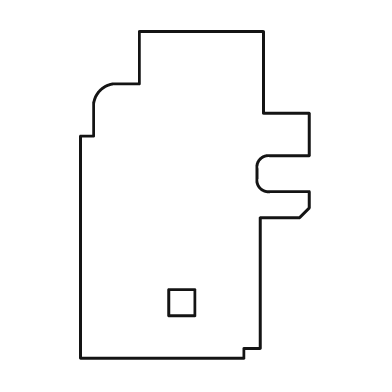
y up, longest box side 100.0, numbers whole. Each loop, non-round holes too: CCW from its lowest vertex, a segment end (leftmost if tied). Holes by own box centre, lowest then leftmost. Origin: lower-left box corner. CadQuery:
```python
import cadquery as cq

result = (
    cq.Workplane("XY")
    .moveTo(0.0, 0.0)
    .lineTo(50.0, 0.0)
    .lineTo(50.0, 3.0)
    .lineTo(55.0, 3.0)
    .lineTo(55.0, 43.0)
    .lineTo(67.0, 43.0)
    .lineTo(70.0, 46.0)
    .lineTo(70.0, 51.0)
    .lineTo(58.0, 51.0)
    .threePointArc((55.0, 52.0), (54.0, 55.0))
    .lineTo(54.0, 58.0)
    .threePointArc((55.0, 61.0), (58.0, 62.0))
    .lineTo(70.0, 62.0)
    .lineTo(70.0, 75.0)
    .lineTo(56.0, 75.0)
    .lineTo(56.0, 100.0)
    .lineTo(18.0, 100.0)
    .lineTo(18.0, 84.0)
    .lineTo(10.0, 84.0)
    .threePointArc((6.0, 82.0), (4.0, 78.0))
    .lineTo(4.0, 68.0)
    .lineTo(0.0, 68.0)
    .close()
    .moveTo(27.0, 13.0)
    .lineTo(35.0, 13.0)
    .lineTo(35.0, 21.0)
    .lineTo(27.0, 21.0)
    .close()
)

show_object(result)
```